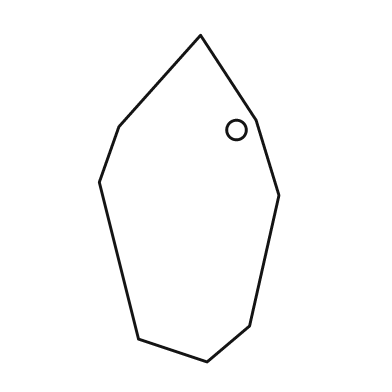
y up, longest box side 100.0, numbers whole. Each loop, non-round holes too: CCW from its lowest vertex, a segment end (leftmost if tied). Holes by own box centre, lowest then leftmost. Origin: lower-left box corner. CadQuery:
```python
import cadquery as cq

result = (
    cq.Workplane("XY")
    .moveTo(33.0, 0.0)
    .lineTo(46.0, 11.0)
    .lineTo(55.0, 51.0)
    .lineTo(48.0, 74.0)
    .lineTo(31.0, 100.0)
    .lineTo(6.0, 72.0)
    .lineTo(0.0, 55.0)
    .lineTo(12.0, 7.0)
    .close()
    .moveTo(42.0, 71.0)
    .circle(3.0)
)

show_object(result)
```